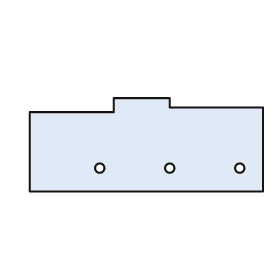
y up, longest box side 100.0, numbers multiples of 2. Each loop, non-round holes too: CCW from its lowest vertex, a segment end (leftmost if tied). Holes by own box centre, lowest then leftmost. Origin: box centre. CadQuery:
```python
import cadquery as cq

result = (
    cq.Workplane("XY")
    .moveTo(-50.0, -20.0)
    .lineTo(50.0, -20.0)
    .lineTo(50.0, 16.0)
    .lineTo(10.0, 16.0)
    .lineTo(10.0, 20.0)
    .lineTo(-14.0, 20.0)
    .lineTo(-14.0, 14.0)
    .lineTo(-50.0, 14.0)
    .close()
    .moveTo(-20.0, -10.0)
    .circle(2.0)
    .moveTo(10.0, -10.0)
    .circle(2.0)
    .moveTo(40.0, -10.0)
    .circle(2.0)
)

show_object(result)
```